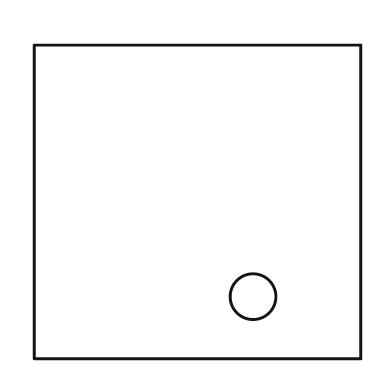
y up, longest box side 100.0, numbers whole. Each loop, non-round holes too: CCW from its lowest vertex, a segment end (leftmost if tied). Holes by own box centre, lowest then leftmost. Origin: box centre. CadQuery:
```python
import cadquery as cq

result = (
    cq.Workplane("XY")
    .moveTo(-50.0, -48.0)
    .lineTo(50.0, -48.0)
    .lineTo(50.0, 48.0)
    .lineTo(-50.0, 48.0)
    .close()
    .moveTo(17.0, -29.0)
    .circle(7.0)
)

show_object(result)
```